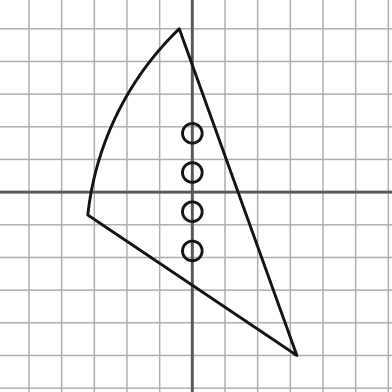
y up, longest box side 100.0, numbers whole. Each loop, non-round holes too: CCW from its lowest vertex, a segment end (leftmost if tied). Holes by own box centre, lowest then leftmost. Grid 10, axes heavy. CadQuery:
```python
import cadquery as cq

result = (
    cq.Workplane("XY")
    .moveTo(32.0, -50.0)
    .lineTo(-4.0, 50.0)
    .threePointArc((-23.0, 24.0), (-32.0, -7.0))
    .close()
    .moveTo(0.0, -18.0)
    .circle(3.0)
    .moveTo(0.0, -6.0)
    .circle(3.0)
    .moveTo(0.0, 6.0)
    .circle(3.0)
    .moveTo(0.0, 18.0)
    .circle(3.0)
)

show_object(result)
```